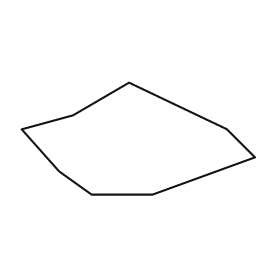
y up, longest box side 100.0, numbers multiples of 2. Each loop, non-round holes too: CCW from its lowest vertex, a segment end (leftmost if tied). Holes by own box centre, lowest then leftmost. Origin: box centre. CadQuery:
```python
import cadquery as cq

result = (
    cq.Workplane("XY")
    .moveTo(-20.0, -24.0)
    .lineTo(6.0, -24.0)
    .lineTo(50.0, -8.0)
    .lineTo(38.0, 4.0)
    .lineTo(-4.0, 24.0)
    .lineTo(-28.0, 10.0)
    .lineTo(-50.0, 4.0)
    .lineTo(-34.0, -14.0)
    .close()
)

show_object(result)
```